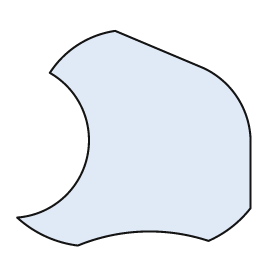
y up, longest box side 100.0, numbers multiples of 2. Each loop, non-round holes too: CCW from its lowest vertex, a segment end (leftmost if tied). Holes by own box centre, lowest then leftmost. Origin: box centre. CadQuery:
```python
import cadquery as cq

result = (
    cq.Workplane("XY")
    .moveTo(-24.0, -46.0)
    .threePointArc((4.0, -40.0), (32.0, -44.0))
    .threePointArc((42.0, -38.0), (50.0, -30.0))
    .lineTo(50.0, 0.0)
    .threePointArc((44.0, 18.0), (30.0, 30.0))
    .lineTo(-8.0, 46.0)
    .threePointArc((-24.0, 40.0), (-36.0, 28.0))
    .threePointArc((-20.0, -8.0), (-50.0, -34.0))
    .threePointArc((-38.0, -42.0), (-24.0, -46.0))
    .close()
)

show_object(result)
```